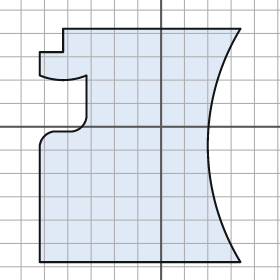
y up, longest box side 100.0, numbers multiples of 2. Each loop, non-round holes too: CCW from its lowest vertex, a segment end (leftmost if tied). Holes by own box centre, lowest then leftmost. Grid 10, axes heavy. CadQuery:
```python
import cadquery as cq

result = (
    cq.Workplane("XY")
    .moveTo(-52.0, -58.0)
    .lineTo(34.0, -58.0)
    .threePointArc((20.0, -8.0), (34.0, 42.0))
    .lineTo(-42.0, 42.0)
    .lineTo(-42.0, 32.0)
    .lineTo(-52.0, 32.0)
    .lineTo(-52.0, 22.0)
    .threePointArc((-42.0, 20.0), (-32.0, 22.0))
    .lineTo(-32.0, 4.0)
    .threePointArc((-34.0, 0.0), (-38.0, -2.0))
    .lineTo(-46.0, -2.0)
    .threePointArc((-50.0, -4.0), (-52.0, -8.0))
    .close()
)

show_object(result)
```